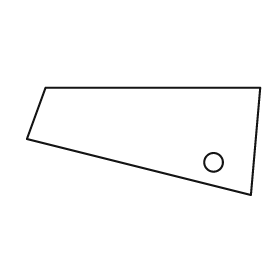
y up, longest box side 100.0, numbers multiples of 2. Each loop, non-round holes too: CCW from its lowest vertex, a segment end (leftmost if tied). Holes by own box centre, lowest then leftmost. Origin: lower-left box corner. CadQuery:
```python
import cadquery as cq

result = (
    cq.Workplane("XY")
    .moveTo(96.0, 0.0)
    .lineTo(100.0, 46.0)
    .lineTo(8.0, 46.0)
    .lineTo(0.0, 24.0)
    .close()
    .moveTo(80.0, 14.0)
    .circle(4.0)
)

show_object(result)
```